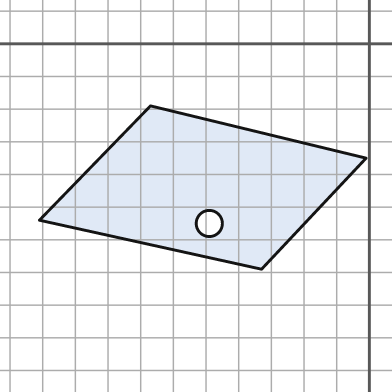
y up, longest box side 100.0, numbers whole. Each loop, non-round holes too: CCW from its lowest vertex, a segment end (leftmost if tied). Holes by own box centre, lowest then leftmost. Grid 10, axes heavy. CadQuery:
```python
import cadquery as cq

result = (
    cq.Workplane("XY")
    .moveTo(-33.0, -69.0)
    .lineTo(-1.0, -35.0)
    .lineTo(-67.0, -19.0)
    .lineTo(-101.0, -54.0)
    .close()
    .moveTo(-49.0, -55.0)
    .circle(4.0)
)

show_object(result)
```